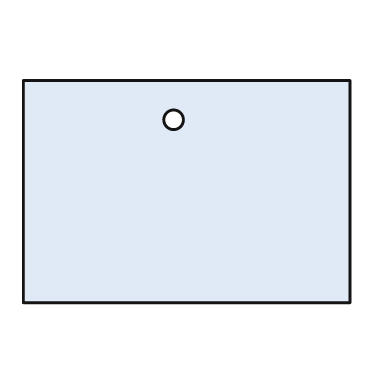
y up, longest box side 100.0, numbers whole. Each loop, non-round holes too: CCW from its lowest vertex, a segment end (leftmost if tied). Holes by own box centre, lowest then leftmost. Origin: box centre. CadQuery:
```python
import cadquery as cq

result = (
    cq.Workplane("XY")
    .moveTo(-50.0, -34.0)
    .lineTo(50.0, -34.0)
    .lineTo(50.0, 34.0)
    .lineTo(-50.0, 34.0)
    .close()
    .moveTo(-4.0, 22.0)
    .circle(3.0)
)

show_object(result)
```